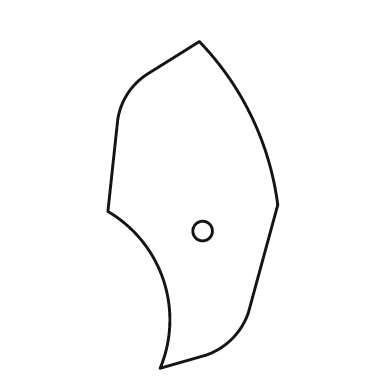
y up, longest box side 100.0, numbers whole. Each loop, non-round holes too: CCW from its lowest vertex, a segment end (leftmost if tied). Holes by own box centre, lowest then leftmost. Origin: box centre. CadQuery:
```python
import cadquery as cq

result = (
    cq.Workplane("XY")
    .moveTo(-10.0, -50.0)
    .lineTo(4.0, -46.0)
    .threePointArc((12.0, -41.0), (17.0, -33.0))
    .lineTo(26.0, 0.0)
    .threePointArc((18.0, 27.0), (2.0, 50.0))
    .lineTo(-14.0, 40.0)
    .threePointArc((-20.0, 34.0), (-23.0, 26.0))
    .lineTo(-26.0, -2.0)
    .threePointArc((-9.0, -23.0), (-10.0, -50.0))
    .close()
    .moveTo(3.0, -8.0)
    .circle(3.0)
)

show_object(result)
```